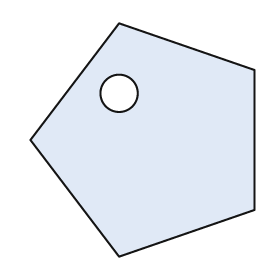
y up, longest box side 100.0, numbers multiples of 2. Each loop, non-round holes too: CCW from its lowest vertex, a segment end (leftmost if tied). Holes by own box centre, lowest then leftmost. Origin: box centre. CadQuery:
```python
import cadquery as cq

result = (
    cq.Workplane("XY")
    .moveTo(-10.0, -50.0)
    .lineTo(48.0, -30.0)
    .lineTo(48.0, 30.0)
    .lineTo(-10.0, 50.0)
    .lineTo(-48.0, 0.0)
    .close()
    .moveTo(-10.0, 20.0)
    .circle(8.0)
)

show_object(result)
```